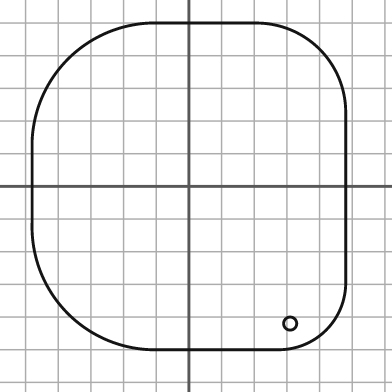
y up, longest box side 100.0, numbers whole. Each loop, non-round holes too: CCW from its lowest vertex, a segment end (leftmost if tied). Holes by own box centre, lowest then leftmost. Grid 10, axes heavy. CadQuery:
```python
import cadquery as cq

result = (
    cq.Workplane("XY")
    .moveTo(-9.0, -50.0)
    .lineTo(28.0, -50.0)
    .threePointArc((42.0, -44.0), (48.0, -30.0))
    .lineTo(48.0, 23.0)
    .threePointArc((40.0, 42.0), (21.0, 50.0))
    .lineTo(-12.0, 50.0)
    .threePointArc((-37.0, 39.0), (-48.0, 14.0))
    .lineTo(-48.0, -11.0)
    .threePointArc((-37.0, -39.0), (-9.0, -50.0))
    .close()
    .moveTo(31.0, -42.0)
    .circle(2.0)
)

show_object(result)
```